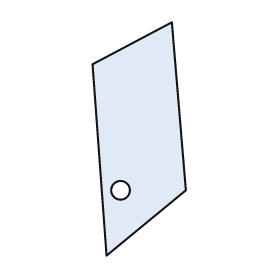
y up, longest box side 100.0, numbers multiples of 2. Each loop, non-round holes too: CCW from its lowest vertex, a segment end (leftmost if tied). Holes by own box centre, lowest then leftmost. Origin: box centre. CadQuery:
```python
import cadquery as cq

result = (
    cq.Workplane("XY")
    .moveTo(-14.0, -50.0)
    .lineTo(20.0, -22.0)
    .lineTo(14.0, 50.0)
    .lineTo(-20.0, 32.0)
    .close()
    .moveTo(-8.0, -22.0)
    .circle(4.0)
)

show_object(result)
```